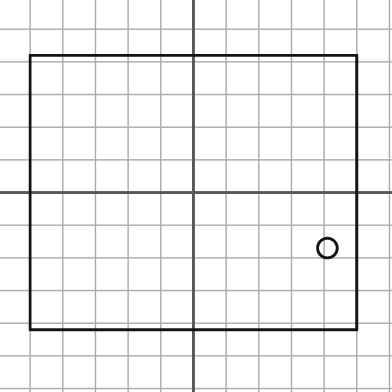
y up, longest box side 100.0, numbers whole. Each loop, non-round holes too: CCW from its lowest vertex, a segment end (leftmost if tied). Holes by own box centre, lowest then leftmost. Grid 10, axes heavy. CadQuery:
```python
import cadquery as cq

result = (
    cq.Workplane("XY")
    .moveTo(-50.0, -42.0)
    .lineTo(50.0, -42.0)
    .lineTo(50.0, 42.0)
    .lineTo(-50.0, 42.0)
    .close()
    .moveTo(41.0, -17.0)
    .circle(3.0)
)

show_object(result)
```